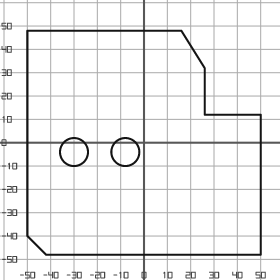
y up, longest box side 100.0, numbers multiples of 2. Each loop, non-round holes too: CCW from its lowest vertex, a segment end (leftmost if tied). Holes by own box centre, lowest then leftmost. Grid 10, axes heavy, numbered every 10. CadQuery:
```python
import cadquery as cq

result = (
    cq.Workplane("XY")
    .moveTo(-42.0, -48.0)
    .lineTo(50.0, -48.0)
    .lineTo(50.0, 12.0)
    .lineTo(26.0, 12.0)
    .lineTo(26.0, 32.0)
    .lineTo(16.0, 48.0)
    .lineTo(-50.0, 48.0)
    .lineTo(-50.0, -40.0)
    .close()
    .moveTo(-30.0, -4.0)
    .circle(6.0)
    .moveTo(-8.0, -4.0)
    .circle(6.0)
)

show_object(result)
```